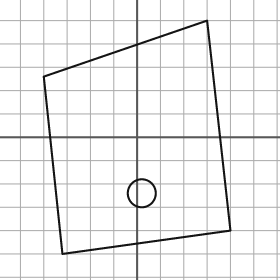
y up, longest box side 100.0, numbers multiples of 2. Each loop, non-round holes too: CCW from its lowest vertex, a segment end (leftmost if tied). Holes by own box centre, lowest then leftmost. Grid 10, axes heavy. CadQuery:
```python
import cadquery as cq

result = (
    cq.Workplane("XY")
    .moveTo(-32.0, -50.0)
    .lineTo(40.0, -40.0)
    .lineTo(30.0, 50.0)
    .lineTo(-40.0, 26.0)
    .close()
    .moveTo(2.0, -24.0)
    .circle(6.0)
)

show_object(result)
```